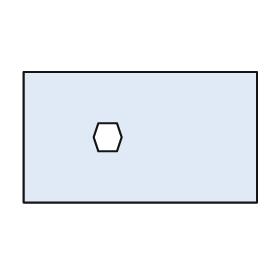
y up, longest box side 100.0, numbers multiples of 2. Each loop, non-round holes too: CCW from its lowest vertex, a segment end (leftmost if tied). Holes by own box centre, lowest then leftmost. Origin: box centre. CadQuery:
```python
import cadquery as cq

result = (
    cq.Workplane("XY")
    .moveTo(-50.0, -28.0)
    .lineTo(50.0, -28.0)
    .lineTo(50.0, 28.0)
    .lineTo(-50.0, 28.0)
    .close()
    .moveTo(-18.0, -6.0)
    .lineTo(-10.0, -6.0)
    .lineTo(-8.0, 0.0)
    .lineTo(-10.0, 6.0)
    .lineTo(-18.0, 6.0)
    .lineTo(-20.0, 0.0)
    .close()
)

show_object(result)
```